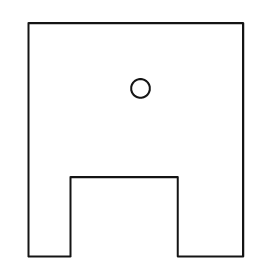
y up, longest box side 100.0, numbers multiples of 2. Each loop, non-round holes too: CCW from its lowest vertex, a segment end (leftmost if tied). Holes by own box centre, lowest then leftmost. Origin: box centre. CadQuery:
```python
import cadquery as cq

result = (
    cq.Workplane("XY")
    .moveTo(-46.0, -50.0)
    .lineTo(-28.0, -50.0)
    .lineTo(-28.0, -16.0)
    .lineTo(18.0, -16.0)
    .lineTo(18.0, -50.0)
    .lineTo(46.0, -50.0)
    .lineTo(46.0, 50.0)
    .lineTo(-46.0, 50.0)
    .close()
    .moveTo(2.0, 22.0)
    .circle(4.0)
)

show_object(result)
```